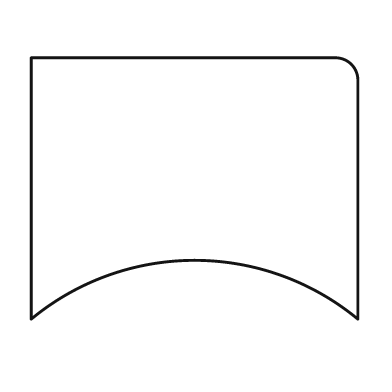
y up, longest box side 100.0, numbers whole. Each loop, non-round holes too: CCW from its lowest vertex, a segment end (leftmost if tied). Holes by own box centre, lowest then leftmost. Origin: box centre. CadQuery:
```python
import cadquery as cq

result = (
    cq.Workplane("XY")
    .moveTo(-50.0, -40.0)
    .threePointArc((0.0, -22.0), (50.0, -40.0))
    .lineTo(50.0, 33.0)
    .threePointArc((48.0, 38.0), (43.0, 40.0))
    .lineTo(-50.0, 40.0)
    .close()
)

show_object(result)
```